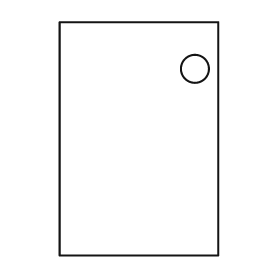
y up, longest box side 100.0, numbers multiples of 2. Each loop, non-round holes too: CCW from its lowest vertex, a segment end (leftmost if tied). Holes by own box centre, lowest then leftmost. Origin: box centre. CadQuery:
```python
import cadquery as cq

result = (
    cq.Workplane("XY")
    .moveTo(-34.0, -50.0)
    .lineTo(34.0, -50.0)
    .lineTo(34.0, 50.0)
    .lineTo(-34.0, 50.0)
    .close()
    .moveTo(24.0, 30.0)
    .circle(6.0)
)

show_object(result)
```